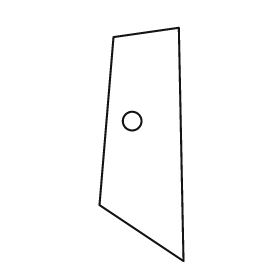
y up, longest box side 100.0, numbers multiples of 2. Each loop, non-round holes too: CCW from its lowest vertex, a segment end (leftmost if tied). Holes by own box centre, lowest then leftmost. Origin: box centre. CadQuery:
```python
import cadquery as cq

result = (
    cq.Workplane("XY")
    .moveTo(18.0, -50.0)
    .lineTo(16.0, 50.0)
    .lineTo(-12.0, 46.0)
    .lineTo(-18.0, -26.0)
    .close()
    .moveTo(-4.0, 10.0)
    .circle(4.0)
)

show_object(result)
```